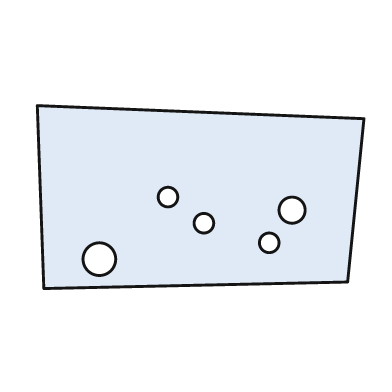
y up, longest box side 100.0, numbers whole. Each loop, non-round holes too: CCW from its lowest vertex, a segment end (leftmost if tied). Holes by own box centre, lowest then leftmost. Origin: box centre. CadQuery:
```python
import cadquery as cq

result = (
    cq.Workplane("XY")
    .moveTo(-48.0, -28.0)
    .lineTo(45.0, -26.0)
    .lineTo(50.0, 24.0)
    .lineTo(-50.0, 28.0)
    .close()
    .moveTo(-31.0, -19.0)
    .circle(5.0)
    .moveTo(21.0, -14.0)
    .circle(3.0)
    .moveTo(1.0, -8.0)
    .circle(3.0)
    .moveTo(28.0, -4.0)
    .circle(4.0)
    .moveTo(-10.0, 0.0)
    .circle(3.0)
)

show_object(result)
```